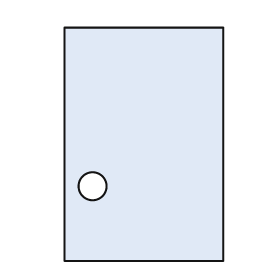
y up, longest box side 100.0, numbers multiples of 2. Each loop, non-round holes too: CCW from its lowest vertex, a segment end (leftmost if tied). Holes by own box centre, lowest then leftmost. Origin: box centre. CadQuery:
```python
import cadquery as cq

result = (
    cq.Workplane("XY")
    .moveTo(-34.0, -50.0)
    .lineTo(34.0, -50.0)
    .lineTo(34.0, 50.0)
    .lineTo(-34.0, 50.0)
    .close()
    .moveTo(-22.0, -18.0)
    .circle(6.0)
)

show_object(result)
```